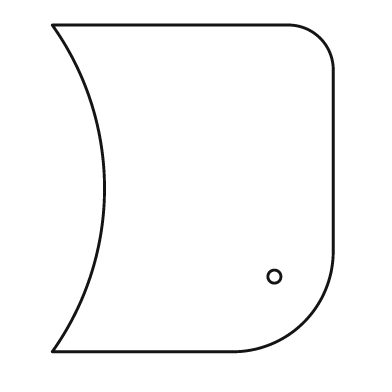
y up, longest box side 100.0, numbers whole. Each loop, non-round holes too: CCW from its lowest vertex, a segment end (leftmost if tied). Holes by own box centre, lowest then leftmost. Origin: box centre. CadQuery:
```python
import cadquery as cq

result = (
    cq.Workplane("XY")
    .moveTo(-43.0, -50.0)
    .lineTo(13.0, -50.0)
    .threePointArc((34.0, -41.0), (43.0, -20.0))
    .lineTo(43.0, 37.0)
    .threePointArc((39.0, 46.0), (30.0, 50.0))
    .lineTo(-43.0, 50.0)
    .threePointArc((-27.0, 0.0), (-43.0, -50.0))
    .close()
    .moveTo(25.0, -27.0)
    .circle(2.0)
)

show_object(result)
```